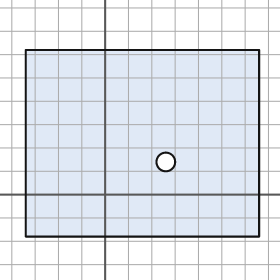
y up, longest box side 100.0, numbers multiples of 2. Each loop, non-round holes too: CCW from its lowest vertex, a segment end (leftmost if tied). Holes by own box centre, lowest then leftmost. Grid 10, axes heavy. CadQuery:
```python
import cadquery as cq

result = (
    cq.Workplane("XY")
    .moveTo(-34.0, -18.0)
    .lineTo(66.0, -18.0)
    .lineTo(66.0, 62.0)
    .lineTo(-34.0, 62.0)
    .close()
    .moveTo(26.0, 14.0)
    .circle(4.0)
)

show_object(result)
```